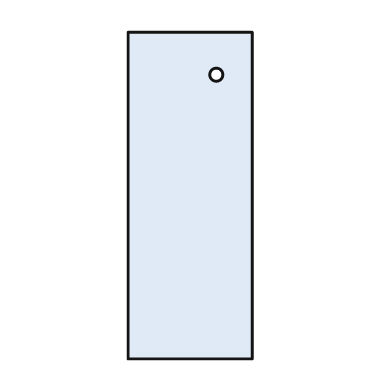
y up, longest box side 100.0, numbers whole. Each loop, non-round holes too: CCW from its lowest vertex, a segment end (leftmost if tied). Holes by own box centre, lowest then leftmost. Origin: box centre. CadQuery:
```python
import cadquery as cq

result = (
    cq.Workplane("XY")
    .moveTo(-19.0, -50.0)
    .lineTo(19.0, -50.0)
    .lineTo(19.0, 50.0)
    .lineTo(-19.0, 50.0)
    .close()
    .moveTo(8.0, 37.0)
    .circle(2.0)
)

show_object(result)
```